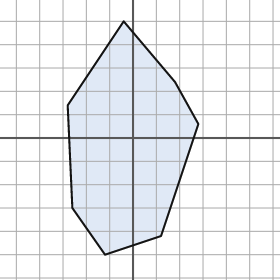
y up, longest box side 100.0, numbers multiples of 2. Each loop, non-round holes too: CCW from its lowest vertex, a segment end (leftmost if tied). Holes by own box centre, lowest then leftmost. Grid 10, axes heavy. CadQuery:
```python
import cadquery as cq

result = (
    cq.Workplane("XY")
    .moveTo(-12.0, -50.0)
    .lineTo(12.0, -42.0)
    .lineTo(28.0, 6.0)
    .lineTo(18.0, 24.0)
    .lineTo(-4.0, 50.0)
    .lineTo(-28.0, 14.0)
    .lineTo(-26.0, -30.0)
    .close()
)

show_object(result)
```